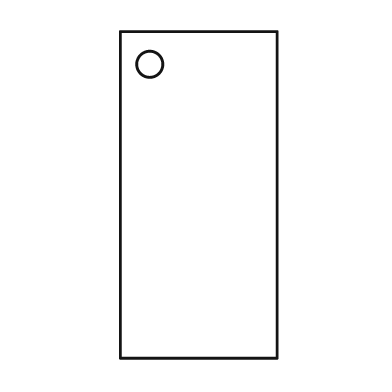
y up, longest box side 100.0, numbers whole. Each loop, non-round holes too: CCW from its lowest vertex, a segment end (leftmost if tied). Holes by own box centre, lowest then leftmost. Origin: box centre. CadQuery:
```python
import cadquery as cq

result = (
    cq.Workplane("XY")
    .moveTo(-24.0, -50.0)
    .lineTo(24.0, -50.0)
    .lineTo(24.0, 50.0)
    .lineTo(-24.0, 50.0)
    .close()
    .moveTo(-15.0, 40.0)
    .circle(4.0)
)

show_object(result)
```